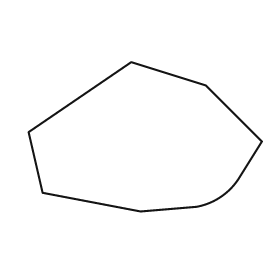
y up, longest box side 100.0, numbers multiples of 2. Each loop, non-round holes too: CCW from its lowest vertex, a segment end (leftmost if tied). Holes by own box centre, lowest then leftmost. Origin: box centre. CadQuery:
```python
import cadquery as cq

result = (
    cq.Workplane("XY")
    .moveTo(-2.0, -32.0)
    .lineTo(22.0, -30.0)
    .threePointArc((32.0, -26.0), (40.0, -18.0))
    .lineTo(50.0, -2.0)
    .lineTo(26.0, 22.0)
    .lineTo(-6.0, 32.0)
    .lineTo(-50.0, 2.0)
    .lineTo(-44.0, -24.0)
    .close()
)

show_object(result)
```